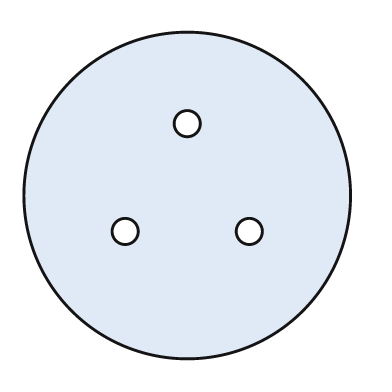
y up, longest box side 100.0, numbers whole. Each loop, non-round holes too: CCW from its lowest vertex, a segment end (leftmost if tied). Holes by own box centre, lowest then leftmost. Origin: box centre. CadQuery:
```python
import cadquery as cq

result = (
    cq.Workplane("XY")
    .moveTo(0.0, 0.0)
    .circle(50.0)
    .moveTo(-19.0, -11.0)
    .circle(4.0)
    .moveTo(19.0, -11.0)
    .circle(4.0)
    .moveTo(0.0, 22.0)
    .circle(4.0)
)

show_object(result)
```